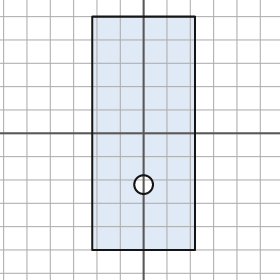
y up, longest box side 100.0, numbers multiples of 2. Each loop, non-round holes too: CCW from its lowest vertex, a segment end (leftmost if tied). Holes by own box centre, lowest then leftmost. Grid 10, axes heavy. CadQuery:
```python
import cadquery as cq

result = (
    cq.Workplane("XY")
    .moveTo(-22.0, -50.0)
    .lineTo(22.0, -50.0)
    .lineTo(22.0, 50.0)
    .lineTo(-22.0, 50.0)
    .close()
    .moveTo(0.0, -22.0)
    .circle(4.0)
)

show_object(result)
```